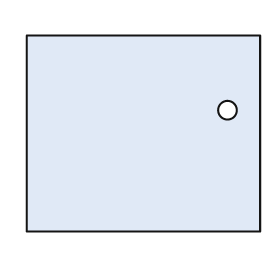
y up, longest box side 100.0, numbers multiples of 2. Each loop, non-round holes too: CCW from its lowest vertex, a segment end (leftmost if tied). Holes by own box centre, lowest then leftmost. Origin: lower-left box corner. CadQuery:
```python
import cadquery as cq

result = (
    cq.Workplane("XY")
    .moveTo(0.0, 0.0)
    .lineTo(100.0, 0.0)
    .lineTo(100.0, 84.0)
    .lineTo(0.0, 84.0)
    .close()
    .moveTo(86.0, 52.0)
    .circle(4.0)
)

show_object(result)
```